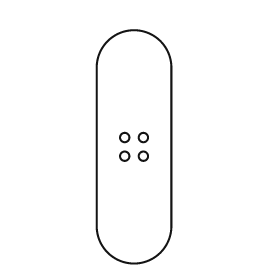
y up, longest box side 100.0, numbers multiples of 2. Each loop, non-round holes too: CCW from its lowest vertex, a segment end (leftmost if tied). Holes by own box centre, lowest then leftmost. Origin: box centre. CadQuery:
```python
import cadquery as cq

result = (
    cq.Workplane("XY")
    .moveTo(-16.0, -34.0)
    .threePointArc((0.0, -50.0), (16.0, -34.0))
    .lineTo(16.0, 34.0)
    .threePointArc((0.0, 50.0), (-16.0, 34.0))
    .close()
    .moveTo(-4.0, -4.0)
    .circle(2.0)
    .moveTo(4.0, -4.0)
    .circle(2.0)
    .moveTo(-4.0, 4.0)
    .circle(2.0)
    .moveTo(4.0, 4.0)
    .circle(2.0)
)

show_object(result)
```